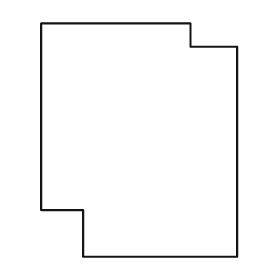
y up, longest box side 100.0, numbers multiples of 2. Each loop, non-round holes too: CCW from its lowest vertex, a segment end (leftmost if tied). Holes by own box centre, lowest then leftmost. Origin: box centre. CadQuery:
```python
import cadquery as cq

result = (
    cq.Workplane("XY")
    .moveTo(-24.0, -50.0)
    .lineTo(42.0, -50.0)
    .lineTo(42.0, 40.0)
    .lineTo(22.0, 40.0)
    .lineTo(22.0, 50.0)
    .lineTo(-42.0, 50.0)
    .lineTo(-42.0, -30.0)
    .lineTo(-24.0, -30.0)
    .close()
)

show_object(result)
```